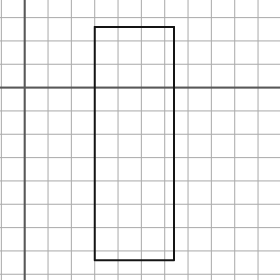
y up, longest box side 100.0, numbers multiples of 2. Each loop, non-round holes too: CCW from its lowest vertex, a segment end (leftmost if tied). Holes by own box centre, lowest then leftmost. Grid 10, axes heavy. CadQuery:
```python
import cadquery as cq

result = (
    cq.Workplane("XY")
    .moveTo(30.0, -74.0)
    .lineTo(64.0, -74.0)
    .lineTo(64.0, 26.0)
    .lineTo(30.0, 26.0)
    .close()
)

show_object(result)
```